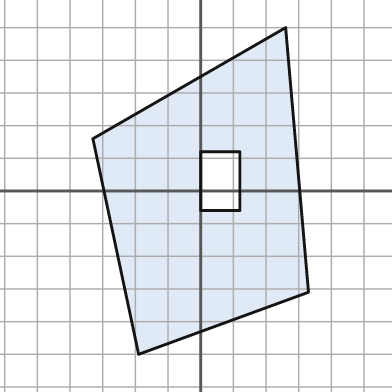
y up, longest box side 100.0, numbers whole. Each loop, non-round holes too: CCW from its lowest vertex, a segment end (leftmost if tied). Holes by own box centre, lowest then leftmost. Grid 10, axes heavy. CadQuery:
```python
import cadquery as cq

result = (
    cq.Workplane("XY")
    .moveTo(-19.0, -50.0)
    .lineTo(33.0, -31.0)
    .lineTo(26.0, 50.0)
    .lineTo(-33.0, 16.0)
    .close()
    .moveTo(0.0, -6.0)
    .lineTo(12.0, -6.0)
    .lineTo(12.0, 12.0)
    .lineTo(0.0, 12.0)
    .close()
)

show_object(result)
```